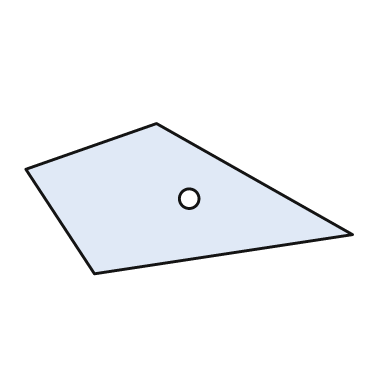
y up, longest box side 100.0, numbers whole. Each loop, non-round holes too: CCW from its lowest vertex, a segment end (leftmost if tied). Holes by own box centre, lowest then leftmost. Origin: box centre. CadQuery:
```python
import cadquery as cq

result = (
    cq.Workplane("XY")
    .moveTo(-29.0, -23.0)
    .lineTo(50.0, -11.0)
    .lineTo(-10.0, 23.0)
    .lineTo(-50.0, 9.0)
    .close()
    .moveTo(0.0, 0.0)
    .circle(3.0)
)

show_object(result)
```